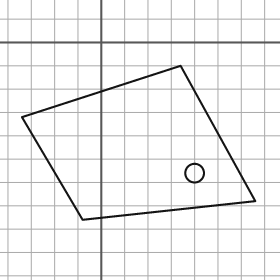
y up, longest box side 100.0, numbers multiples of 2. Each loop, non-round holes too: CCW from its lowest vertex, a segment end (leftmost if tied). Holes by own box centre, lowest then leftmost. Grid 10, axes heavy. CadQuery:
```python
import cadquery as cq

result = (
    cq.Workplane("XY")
    .moveTo(-8.0, -76.0)
    .lineTo(66.0, -68.0)
    .lineTo(34.0, -10.0)
    .lineTo(-34.0, -32.0)
    .close()
    .moveTo(40.0, -56.0)
    .circle(4.0)
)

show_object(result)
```